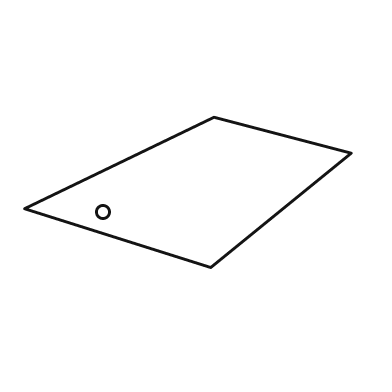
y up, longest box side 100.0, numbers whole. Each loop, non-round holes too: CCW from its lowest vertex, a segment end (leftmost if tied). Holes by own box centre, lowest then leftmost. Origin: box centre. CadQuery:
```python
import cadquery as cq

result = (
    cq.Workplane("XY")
    .moveTo(7.0, -23.0)
    .lineTo(50.0, 12.0)
    .lineTo(8.0, 23.0)
    .lineTo(-50.0, -5.0)
    .close()
    .moveTo(-26.0, -6.0)
    .circle(2.0)
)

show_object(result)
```